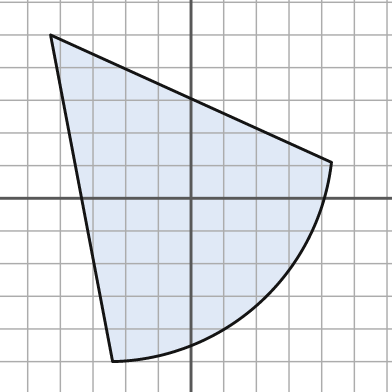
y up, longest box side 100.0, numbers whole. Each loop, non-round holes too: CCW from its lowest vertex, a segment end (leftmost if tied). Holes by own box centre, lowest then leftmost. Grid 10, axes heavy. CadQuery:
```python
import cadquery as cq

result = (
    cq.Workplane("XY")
    .moveTo(-24.0, -50.0)
    .threePointArc((21.0, -32.0), (43.0, 11.0))
    .lineTo(-43.0, 50.0)
    .close()
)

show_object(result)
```